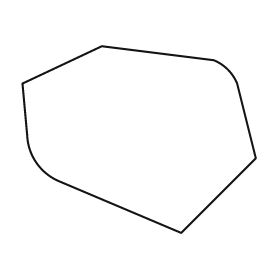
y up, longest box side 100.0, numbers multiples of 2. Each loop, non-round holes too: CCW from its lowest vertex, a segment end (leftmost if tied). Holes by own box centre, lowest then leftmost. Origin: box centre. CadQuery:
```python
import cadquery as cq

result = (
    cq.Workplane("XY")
    .moveTo(18.0, -40.0)
    .lineTo(50.0, -8.0)
    .lineTo(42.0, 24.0)
    .threePointArc((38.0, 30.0), (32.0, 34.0))
    .lineTo(-16.0, 40.0)
    .lineTo(-50.0, 24.0)
    .lineTo(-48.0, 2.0)
    .threePointArc((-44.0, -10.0), (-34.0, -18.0))
    .close()
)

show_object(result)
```